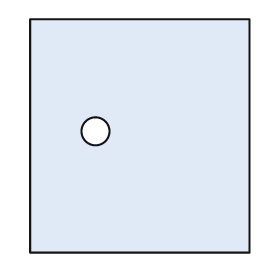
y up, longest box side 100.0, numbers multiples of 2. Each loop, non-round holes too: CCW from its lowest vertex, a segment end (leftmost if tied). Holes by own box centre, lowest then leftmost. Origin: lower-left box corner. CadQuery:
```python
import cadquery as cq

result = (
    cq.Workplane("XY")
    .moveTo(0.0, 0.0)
    .lineTo(94.0, 0.0)
    .lineTo(94.0, 100.0)
    .lineTo(0.0, 100.0)
    .close()
    .moveTo(28.0, 52.0)
    .circle(6.0)
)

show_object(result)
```